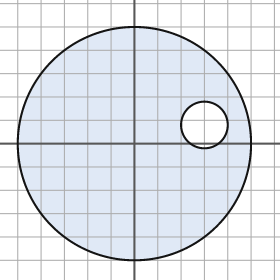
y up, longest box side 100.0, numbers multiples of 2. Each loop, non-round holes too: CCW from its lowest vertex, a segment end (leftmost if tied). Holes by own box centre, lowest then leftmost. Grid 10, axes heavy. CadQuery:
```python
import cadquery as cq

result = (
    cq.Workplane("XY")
    .moveTo(0.0, 0.0)
    .circle(50.0)
    .moveTo(30.0, 8.0)
    .circle(10.0)
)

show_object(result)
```